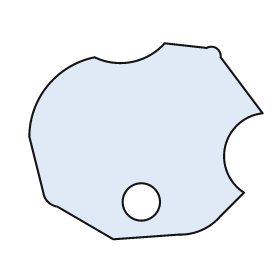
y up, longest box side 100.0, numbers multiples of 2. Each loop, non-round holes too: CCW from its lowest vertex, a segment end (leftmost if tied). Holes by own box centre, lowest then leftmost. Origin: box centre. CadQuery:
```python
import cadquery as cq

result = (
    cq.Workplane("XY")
    .moveTo(-14.0, -42.0)
    .lineTo(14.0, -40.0)
    .threePointArc((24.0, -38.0), (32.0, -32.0))
    .lineTo(42.0, -22.0)
    .threePointArc((34.0, -2.0), (50.0, 12.0))
    .lineTo(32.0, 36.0)
    .threePointArc((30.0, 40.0), (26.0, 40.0))
    .lineTo(8.0, 42.0)
    .threePointArc((-6.0, 34.0), (-22.0, 36.0))
    .threePointArc((-42.0, 24.0), (-50.0, 2.0))
    .lineTo(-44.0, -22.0)
    .threePointArc((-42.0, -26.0), (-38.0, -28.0))
    .close()
    .moveTo(-2.0, -26.0)
    .circle(8.0)
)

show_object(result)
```